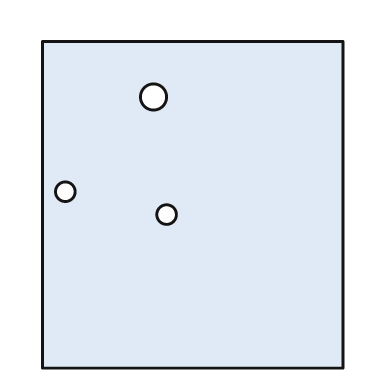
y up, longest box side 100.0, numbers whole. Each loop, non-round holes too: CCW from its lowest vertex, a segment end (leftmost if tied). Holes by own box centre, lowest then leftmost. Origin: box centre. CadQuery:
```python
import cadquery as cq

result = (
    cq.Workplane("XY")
    .moveTo(-46.0, -50.0)
    .lineTo(46.0, -50.0)
    .lineTo(46.0, 50.0)
    .lineTo(-46.0, 50.0)
    .close()
    .moveTo(-8.0, -3.0)
    .circle(3.0)
    .moveTo(-39.0, 4.0)
    .circle(3.0)
    .moveTo(-12.0, 33.0)
    .circle(4.0)
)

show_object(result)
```